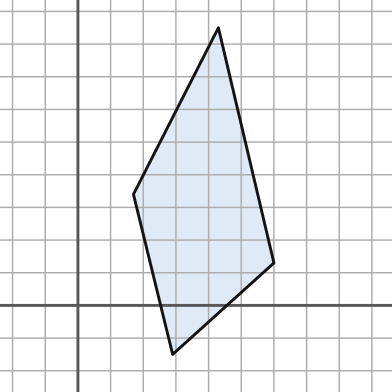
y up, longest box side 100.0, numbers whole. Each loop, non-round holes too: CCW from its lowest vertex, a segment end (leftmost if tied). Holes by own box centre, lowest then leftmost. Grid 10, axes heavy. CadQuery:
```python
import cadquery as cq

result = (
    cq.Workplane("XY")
    .moveTo(29.0, -15.0)
    .lineTo(60.0, 13.0)
    .lineTo(43.0, 85.0)
    .lineTo(17.0, 34.0)
    .close()
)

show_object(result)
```